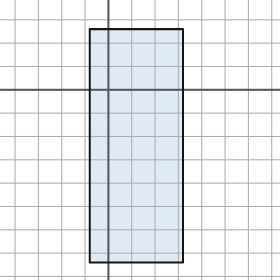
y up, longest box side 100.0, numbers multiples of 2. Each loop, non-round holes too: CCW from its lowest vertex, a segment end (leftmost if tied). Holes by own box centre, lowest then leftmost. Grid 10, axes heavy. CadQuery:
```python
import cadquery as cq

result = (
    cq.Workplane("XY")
    .moveTo(-8.0, -74.0)
    .lineTo(32.0, -74.0)
    .lineTo(32.0, 26.0)
    .lineTo(-8.0, 26.0)
    .close()
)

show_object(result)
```